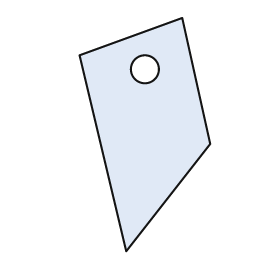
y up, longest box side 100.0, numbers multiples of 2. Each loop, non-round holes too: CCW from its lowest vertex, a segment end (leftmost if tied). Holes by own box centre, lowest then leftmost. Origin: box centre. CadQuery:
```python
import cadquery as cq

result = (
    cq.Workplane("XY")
    .moveTo(-8.0, -50.0)
    .lineTo(28.0, -4.0)
    .lineTo(16.0, 50.0)
    .lineTo(-28.0, 34.0)
    .close()
    .moveTo(0.0, 28.0)
    .circle(6.0)
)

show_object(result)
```